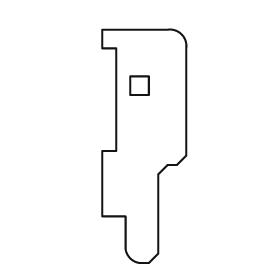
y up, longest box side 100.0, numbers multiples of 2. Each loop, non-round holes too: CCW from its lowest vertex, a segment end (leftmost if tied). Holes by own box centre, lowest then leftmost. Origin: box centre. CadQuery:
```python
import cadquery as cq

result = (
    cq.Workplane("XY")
    .moveTo(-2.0, -50.0)
    .lineTo(2.0, -50.0)
    .lineTo(6.0, -46.0)
    .lineTo(6.0, -12.0)
    .lineTo(10.0, -8.0)
    .lineTo(14.0, -8.0)
    .lineTo(18.0, -4.0)
    .lineTo(18.0, 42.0)
    .threePointArc((16.0, 48.0), (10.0, 50.0))
    .lineTo(-18.0, 50.0)
    .lineTo(-18.0, 42.0)
    .lineTo(-12.0, 42.0)
    .lineTo(-12.0, -2.0)
    .lineTo(-18.0, -2.0)
    .lineTo(-18.0, -30.0)
    .lineTo(-8.0, -30.0)
    .lineTo(-8.0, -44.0)
    .threePointArc((-6.0, -48.0), (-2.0, -50.0))
    .close()
    .moveTo(-6.0, 22.0)
    .lineTo(2.0, 22.0)
    .lineTo(2.0, 30.0)
    .lineTo(-6.0, 30.0)
    .close()
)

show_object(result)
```